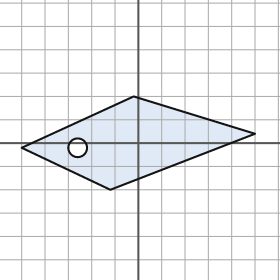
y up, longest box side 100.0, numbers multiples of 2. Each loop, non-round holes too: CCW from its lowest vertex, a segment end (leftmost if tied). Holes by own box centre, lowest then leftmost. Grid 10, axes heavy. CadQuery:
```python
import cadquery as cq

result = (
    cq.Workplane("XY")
    .moveTo(-12.0, -20.0)
    .lineTo(50.0, 4.0)
    .lineTo(-2.0, 20.0)
    .lineTo(-50.0, -2.0)
    .close()
    .moveTo(-26.0, -2.0)
    .circle(4.0)
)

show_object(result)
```